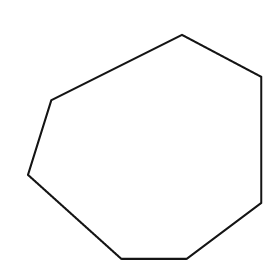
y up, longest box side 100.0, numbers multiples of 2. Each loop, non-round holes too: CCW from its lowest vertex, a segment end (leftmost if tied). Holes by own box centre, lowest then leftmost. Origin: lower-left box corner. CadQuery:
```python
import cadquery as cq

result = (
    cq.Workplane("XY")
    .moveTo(40.0, 0.0)
    .lineTo(68.0, 0.0)
    .lineTo(100.0, 24.0)
    .lineTo(100.0, 78.0)
    .lineTo(66.0, 96.0)
    .lineTo(10.0, 68.0)
    .lineTo(0.0, 36.0)
    .close()
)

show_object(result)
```